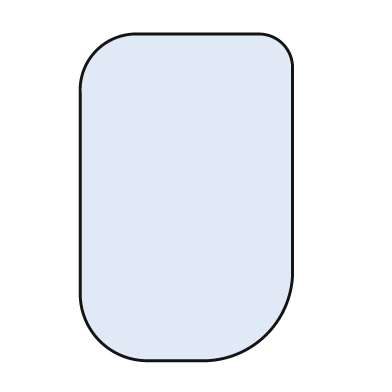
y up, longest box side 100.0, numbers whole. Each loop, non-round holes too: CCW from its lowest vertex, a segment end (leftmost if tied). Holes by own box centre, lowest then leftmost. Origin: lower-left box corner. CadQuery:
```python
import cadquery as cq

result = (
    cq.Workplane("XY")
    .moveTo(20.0, 0.0)
    .lineTo(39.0, 0.0)
    .threePointArc((57.0, 8.0), (65.0, 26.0))
    .lineTo(65.0, 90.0)
    .threePointArc((62.0, 97.0), (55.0, 100.0))
    .lineTo(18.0, 100.0)
    .threePointArc((5.0, 95.0), (0.0, 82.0))
    .lineTo(0.0, 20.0)
    .threePointArc((6.0, 6.0), (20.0, 0.0))
    .close()
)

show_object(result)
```